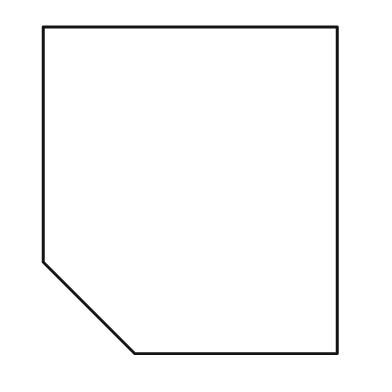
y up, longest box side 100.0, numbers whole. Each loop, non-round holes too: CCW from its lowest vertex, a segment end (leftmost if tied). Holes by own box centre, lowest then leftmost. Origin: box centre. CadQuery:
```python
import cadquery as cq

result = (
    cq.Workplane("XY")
    .moveTo(-17.0, -50.0)
    .lineTo(45.0, -50.0)
    .lineTo(45.0, 50.0)
    .lineTo(-45.0, 50.0)
    .lineTo(-45.0, -22.0)
    .close()
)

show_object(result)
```